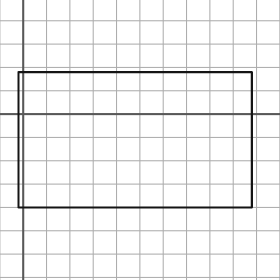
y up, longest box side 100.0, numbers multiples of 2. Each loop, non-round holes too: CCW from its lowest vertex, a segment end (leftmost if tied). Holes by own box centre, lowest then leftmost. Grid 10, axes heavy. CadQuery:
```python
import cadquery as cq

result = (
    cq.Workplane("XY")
    .moveTo(-2.0, -40.0)
    .lineTo(98.0, -40.0)
    .lineTo(98.0, 18.0)
    .lineTo(-2.0, 18.0)
    .close()
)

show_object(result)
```